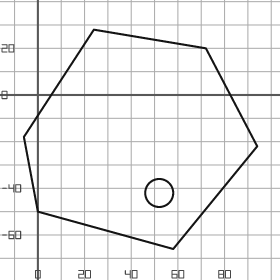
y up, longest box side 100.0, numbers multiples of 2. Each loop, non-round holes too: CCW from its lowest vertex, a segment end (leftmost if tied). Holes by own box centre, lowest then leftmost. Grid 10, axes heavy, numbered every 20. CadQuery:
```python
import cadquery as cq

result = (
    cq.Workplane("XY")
    .moveTo(58.0, -66.0)
    .lineTo(94.0, -22.0)
    .lineTo(72.0, 20.0)
    .lineTo(24.0, 28.0)
    .lineTo(-6.0, -18.0)
    .lineTo(0.0, -50.0)
    .close()
    .moveTo(52.0, -42.0)
    .circle(6.0)
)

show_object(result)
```